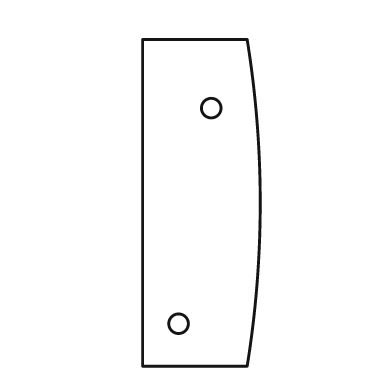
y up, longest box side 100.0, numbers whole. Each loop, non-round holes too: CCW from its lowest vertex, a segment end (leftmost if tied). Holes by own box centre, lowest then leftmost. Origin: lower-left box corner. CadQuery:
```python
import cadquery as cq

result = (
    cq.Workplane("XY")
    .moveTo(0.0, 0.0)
    .lineTo(32.0, 0.0)
    .threePointArc((36.0, 50.0), (32.0, 100.0))
    .lineTo(0.0, 100.0)
    .close()
    .moveTo(11.0, 13.0)
    .circle(3.0)
    .moveTo(21.0, 79.0)
    .circle(3.0)
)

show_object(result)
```